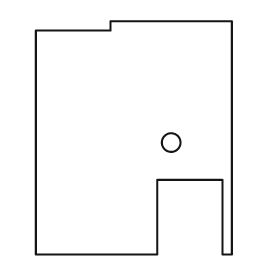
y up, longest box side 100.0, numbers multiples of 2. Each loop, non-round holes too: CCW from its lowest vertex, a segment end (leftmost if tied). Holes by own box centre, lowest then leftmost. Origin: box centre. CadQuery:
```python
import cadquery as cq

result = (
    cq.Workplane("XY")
    .moveTo(-42.0, -50.0)
    .lineTo(10.0, -50.0)
    .lineTo(10.0, -18.0)
    .lineTo(38.0, -18.0)
    .lineTo(38.0, -50.0)
    .lineTo(42.0, -50.0)
    .lineTo(42.0, 50.0)
    .lineTo(-10.0, 50.0)
    .lineTo(-10.0, 46.0)
    .lineTo(-42.0, 46.0)
    .close()
    .moveTo(16.0, -2.0)
    .circle(4.0)
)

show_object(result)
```